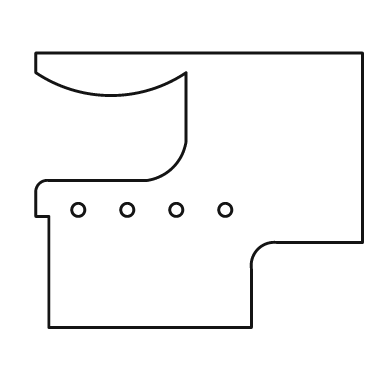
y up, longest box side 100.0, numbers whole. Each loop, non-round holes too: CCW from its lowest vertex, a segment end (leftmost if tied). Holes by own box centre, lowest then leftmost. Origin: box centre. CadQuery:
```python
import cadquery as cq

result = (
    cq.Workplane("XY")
    .moveTo(-46.0, -42.0)
    .lineTo(16.0, -42.0)
    .lineTo(16.0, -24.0)
    .threePointArc((18.0, -18.0), (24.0, -16.0))
    .lineTo(50.0, -16.0)
    .lineTo(50.0, 42.0)
    .lineTo(-50.0, 42.0)
    .lineTo(-50.0, 36.0)
    .threePointArc((-27.0, 29.0), (-4.0, 36.0))
    .lineTo(-4.0, 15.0)
    .threePointArc((-8.0, 7.0), (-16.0, 3.0))
    .lineTo(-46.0, 3.0)
    .threePointArc((-49.0, 2.0), (-50.0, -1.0))
    .lineTo(-50.0, -8.0)
    .lineTo(-46.0, -8.0)
    .close()
    .moveTo(-37.0, -6.0)
    .circle(2.0)
    .moveTo(-22.0, -6.0)
    .circle(2.0)
    .moveTo(-7.0, -6.0)
    .circle(2.0)
    .moveTo(8.0, -6.0)
    .circle(2.0)
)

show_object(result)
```